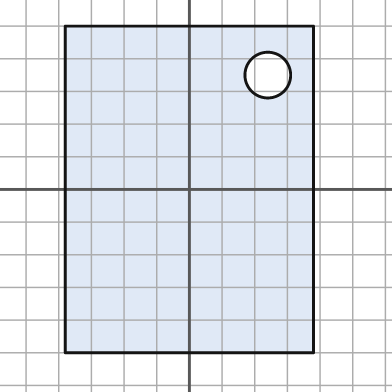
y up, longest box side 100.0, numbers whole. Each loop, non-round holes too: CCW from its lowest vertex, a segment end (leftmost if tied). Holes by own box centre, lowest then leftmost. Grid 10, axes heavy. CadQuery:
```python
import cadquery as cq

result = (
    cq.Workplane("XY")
    .moveTo(-38.0, -50.0)
    .lineTo(38.0, -50.0)
    .lineTo(38.0, 50.0)
    .lineTo(-38.0, 50.0)
    .close()
    .moveTo(24.0, 35.0)
    .circle(7.0)
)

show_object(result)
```